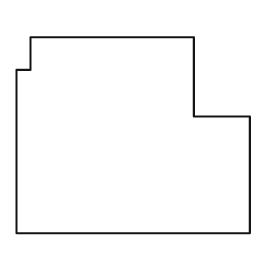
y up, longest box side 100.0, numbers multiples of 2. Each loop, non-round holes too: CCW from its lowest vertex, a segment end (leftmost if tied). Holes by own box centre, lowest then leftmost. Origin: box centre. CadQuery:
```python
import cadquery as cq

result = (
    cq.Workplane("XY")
    .moveTo(-50.0, -42.0)
    .lineTo(50.0, -42.0)
    .lineTo(50.0, 8.0)
    .lineTo(26.0, 8.0)
    .lineTo(26.0, 42.0)
    .lineTo(-44.0, 42.0)
    .lineTo(-44.0, 28.0)
    .lineTo(-50.0, 28.0)
    .close()
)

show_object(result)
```